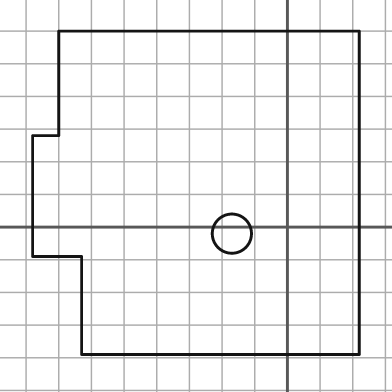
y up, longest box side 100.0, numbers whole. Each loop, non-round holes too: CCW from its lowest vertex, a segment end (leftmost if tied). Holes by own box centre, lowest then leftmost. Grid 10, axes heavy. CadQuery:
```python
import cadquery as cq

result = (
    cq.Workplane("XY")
    .moveTo(-63.0, -39.0)
    .lineTo(22.0, -39.0)
    .lineTo(22.0, 60.0)
    .lineTo(-70.0, 60.0)
    .lineTo(-70.0, 28.0)
    .lineTo(-78.0, 28.0)
    .lineTo(-78.0, -9.0)
    .lineTo(-63.0, -9.0)
    .close()
    .moveTo(-17.0, -2.0)
    .circle(6.0)
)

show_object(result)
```